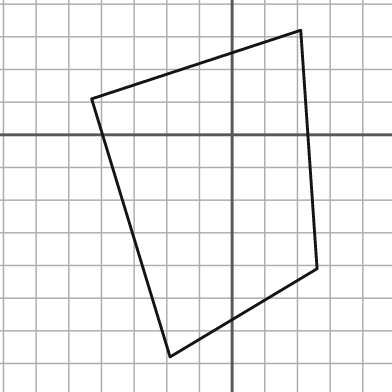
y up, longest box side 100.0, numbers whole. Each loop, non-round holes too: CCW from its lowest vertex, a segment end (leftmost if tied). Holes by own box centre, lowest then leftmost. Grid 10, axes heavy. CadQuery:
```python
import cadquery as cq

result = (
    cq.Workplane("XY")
    .moveTo(-19.0, -68.0)
    .lineTo(26.0, -41.0)
    .lineTo(21.0, 32.0)
    .lineTo(-43.0, 11.0)
    .close()
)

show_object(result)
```